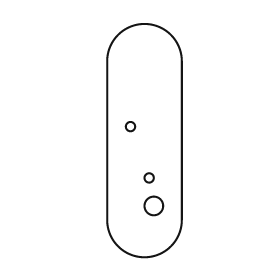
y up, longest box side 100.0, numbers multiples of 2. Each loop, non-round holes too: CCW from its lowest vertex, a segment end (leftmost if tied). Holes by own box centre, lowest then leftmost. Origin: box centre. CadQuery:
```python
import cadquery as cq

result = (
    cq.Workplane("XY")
    .moveTo(-16.0, -34.0)
    .threePointArc((0.0, -50.0), (16.0, -34.0))
    .lineTo(16.0, 34.0)
    .threePointArc((0.0, 50.0), (-16.0, 34.0))
    .close()
    .moveTo(4.0, -28.0)
    .circle(4.0)
    .moveTo(2.0, -16.0)
    .circle(2.0)
    .moveTo(-6.0, 6.0)
    .circle(2.0)
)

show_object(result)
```